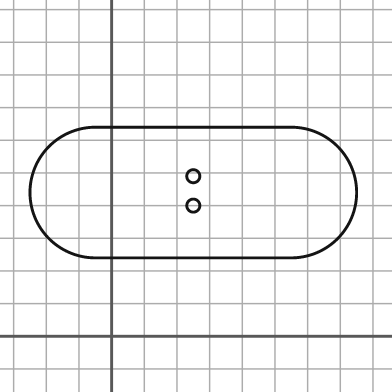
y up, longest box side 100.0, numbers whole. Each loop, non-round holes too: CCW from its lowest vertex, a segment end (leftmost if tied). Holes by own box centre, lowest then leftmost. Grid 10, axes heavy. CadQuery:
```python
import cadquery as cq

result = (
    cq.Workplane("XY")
    .moveTo(-5.0, 24.0)
    .lineTo(55.0, 24.0)
    .threePointArc((75.0, 44.0), (55.0, 64.0))
    .lineTo(-5.0, 64.0)
    .threePointArc((-25.0, 44.0), (-5.0, 24.0))
    .close()
    .moveTo(25.0, 40.0)
    .circle(2.0)
    .moveTo(25.0, 49.0)
    .circle(2.0)
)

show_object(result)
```